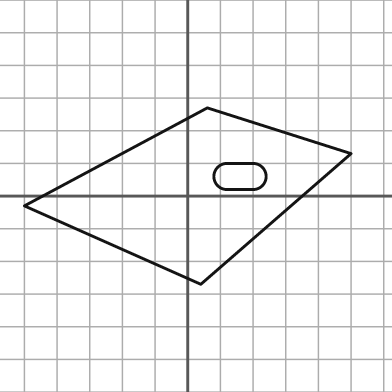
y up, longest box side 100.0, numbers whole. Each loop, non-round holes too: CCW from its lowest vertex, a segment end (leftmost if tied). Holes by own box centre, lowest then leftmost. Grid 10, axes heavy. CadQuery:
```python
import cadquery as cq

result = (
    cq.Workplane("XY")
    .moveTo(4.0, -27.0)
    .lineTo(50.0, 13.0)
    .lineTo(6.0, 27.0)
    .lineTo(-50.0, -3.0)
    .close()
    .moveTo(12.0, 2.0)
    .lineTo(20.0, 2.0)
    .threePointArc((24.0, 6.0), (20.0, 10.0))
    .lineTo(12.0, 10.0)
    .threePointArc((8.0, 6.0), (12.0, 2.0))
    .close()
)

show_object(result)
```